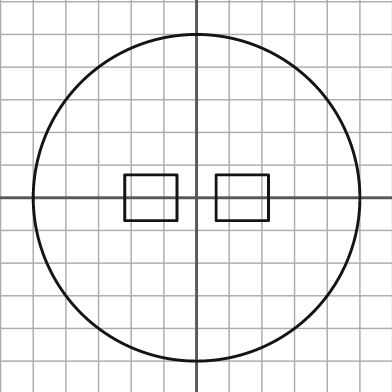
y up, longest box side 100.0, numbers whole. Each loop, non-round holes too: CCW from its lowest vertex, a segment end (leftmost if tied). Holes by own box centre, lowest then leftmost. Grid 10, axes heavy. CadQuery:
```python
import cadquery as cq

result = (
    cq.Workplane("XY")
    .moveTo(0.0, 0.0)
    .circle(50.0)
    .moveTo(-22.0, -7.0)
    .lineTo(-6.0, -7.0)
    .lineTo(-6.0, 7.0)
    .lineTo(-22.0, 7.0)
    .close()
    .moveTo(6.0, -7.0)
    .lineTo(22.0, -7.0)
    .lineTo(22.0, 7.0)
    .lineTo(6.0, 7.0)
    .close()
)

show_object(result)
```